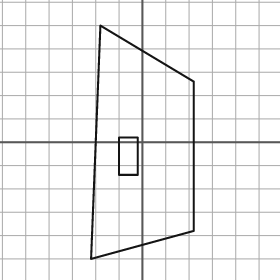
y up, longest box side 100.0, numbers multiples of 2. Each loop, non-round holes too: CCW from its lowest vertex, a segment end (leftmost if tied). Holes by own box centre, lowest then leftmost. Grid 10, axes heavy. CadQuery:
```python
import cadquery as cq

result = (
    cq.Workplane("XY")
    .moveTo(-22.0, -50.0)
    .lineTo(22.0, -38.0)
    .lineTo(22.0, 26.0)
    .lineTo(-18.0, 50.0)
    .close()
    .moveTo(-10.0, -14.0)
    .lineTo(-2.0, -14.0)
    .lineTo(-2.0, 2.0)
    .lineTo(-10.0, 2.0)
    .close()
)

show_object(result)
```